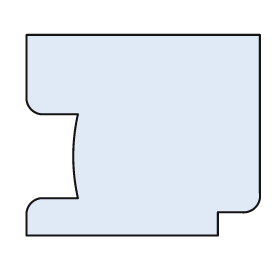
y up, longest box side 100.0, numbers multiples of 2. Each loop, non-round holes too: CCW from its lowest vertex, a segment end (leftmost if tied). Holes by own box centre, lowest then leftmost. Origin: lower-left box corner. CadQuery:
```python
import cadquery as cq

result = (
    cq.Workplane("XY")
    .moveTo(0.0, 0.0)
    .lineTo(82.0, 0.0)
    .lineTo(82.0, 10.0)
    .lineTo(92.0, 10.0)
    .threePointArc((98.0, 12.0), (100.0, 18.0))
    .lineTo(100.0, 86.0)
    .lineTo(0.0, 86.0)
    .lineTo(0.0, 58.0)
    .threePointArc((2.0, 54.0), (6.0, 52.0))
    .lineTo(22.0, 52.0)
    .threePointArc((20.0, 34.0), (22.0, 16.0))
    .lineTo(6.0, 16.0)
    .threePointArc((2.0, 14.0), (0.0, 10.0))
    .close()
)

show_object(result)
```